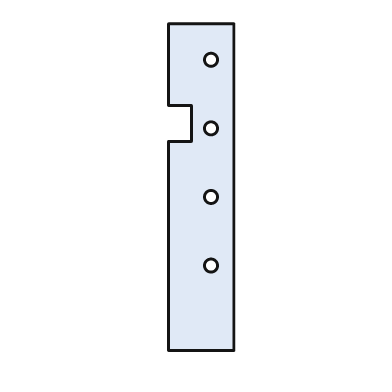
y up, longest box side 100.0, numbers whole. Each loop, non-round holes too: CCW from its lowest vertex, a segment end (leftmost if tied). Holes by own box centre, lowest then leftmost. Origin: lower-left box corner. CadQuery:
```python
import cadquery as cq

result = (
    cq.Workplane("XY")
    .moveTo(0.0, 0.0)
    .lineTo(20.0, 0.0)
    .lineTo(20.0, 100.0)
    .lineTo(0.0, 100.0)
    .lineTo(0.0, 75.0)
    .lineTo(7.0, 75.0)
    .lineTo(7.0, 64.0)
    .lineTo(0.0, 64.0)
    .close()
    .moveTo(13.0, 26.0)
    .circle(2.0)
    .moveTo(13.0, 47.0)
    .circle(2.0)
    .moveTo(13.0, 68.0)
    .circle(2.0)
    .moveTo(13.0, 89.0)
    .circle(2.0)
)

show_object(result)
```